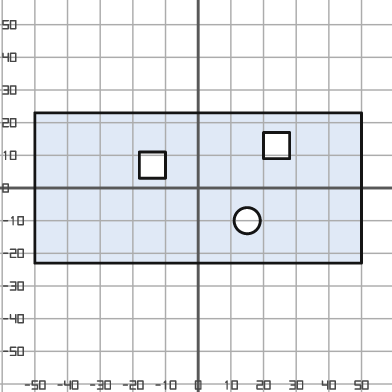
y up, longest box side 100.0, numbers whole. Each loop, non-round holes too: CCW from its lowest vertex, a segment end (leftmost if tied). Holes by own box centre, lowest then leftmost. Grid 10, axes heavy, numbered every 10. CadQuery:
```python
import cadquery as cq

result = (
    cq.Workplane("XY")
    .moveTo(-50.0, -23.0)
    .lineTo(50.0, -23.0)
    .lineTo(50.0, 23.0)
    .lineTo(-50.0, 23.0)
    .close()
    .moveTo(15.0, -10.0)
    .circle(4.0)
    .moveTo(-18.0, 3.0)
    .lineTo(-10.0, 3.0)
    .lineTo(-10.0, 11.0)
    .lineTo(-18.0, 11.0)
    .close()
    .moveTo(20.0, 9.0)
    .lineTo(28.0, 9.0)
    .lineTo(28.0, 17.0)
    .lineTo(20.0, 17.0)
    .close()
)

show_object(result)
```